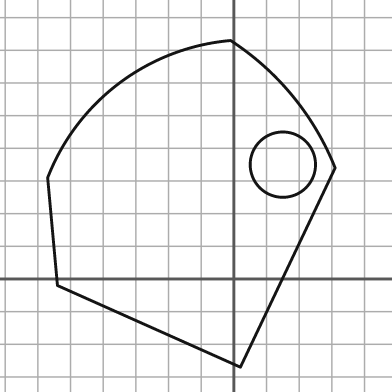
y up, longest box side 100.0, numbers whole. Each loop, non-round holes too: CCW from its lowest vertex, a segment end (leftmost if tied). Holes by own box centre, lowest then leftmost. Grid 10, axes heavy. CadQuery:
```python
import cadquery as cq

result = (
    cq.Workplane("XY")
    .moveTo(2.0, -27.0)
    .lineTo(31.0, 34.0)
    .threePointArc((18.0, 56.0), (-1.0, 73.0))
    .threePointArc((-35.0, 60.0), (-57.0, 31.0))
    .lineTo(-54.0, -2.0)
    .close()
    .moveTo(15.0, 35.0)
    .circle(10.0)
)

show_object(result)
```